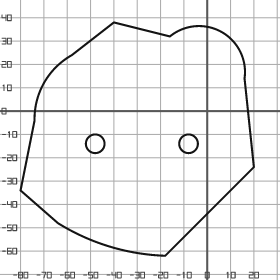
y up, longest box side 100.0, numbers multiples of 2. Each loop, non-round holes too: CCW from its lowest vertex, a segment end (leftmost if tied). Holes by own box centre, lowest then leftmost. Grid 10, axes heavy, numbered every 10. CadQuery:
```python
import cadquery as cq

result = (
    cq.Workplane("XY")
    .moveTo(-18.0, -62.0)
    .lineTo(20.0, -24.0)
    .lineTo(16.0, 14.0)
    .threePointArc((6.0, 34.0), (-16.0, 32.0))
    .lineTo(-40.0, 38.0)
    .lineTo(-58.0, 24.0)
    .threePointArc((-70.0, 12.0), (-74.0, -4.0))
    .lineTo(-80.0, -34.0)
    .lineTo(-64.0, -48.0)
    .threePointArc((-42.0, -58.0), (-18.0, -62.0))
    .close()
    .moveTo(-48.0, -14.0)
    .circle(4.0)
    .moveTo(-8.0, -14.0)
    .circle(4.0)
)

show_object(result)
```